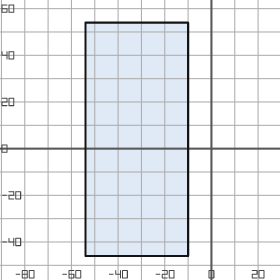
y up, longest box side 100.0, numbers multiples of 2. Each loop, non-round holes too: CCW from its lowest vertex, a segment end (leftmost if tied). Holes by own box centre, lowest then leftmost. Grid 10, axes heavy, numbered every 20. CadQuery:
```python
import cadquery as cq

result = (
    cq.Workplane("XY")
    .moveTo(-54.0, -46.0)
    .lineTo(-10.0, -46.0)
    .lineTo(-10.0, 54.0)
    .lineTo(-54.0, 54.0)
    .close()
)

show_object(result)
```